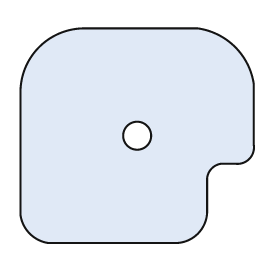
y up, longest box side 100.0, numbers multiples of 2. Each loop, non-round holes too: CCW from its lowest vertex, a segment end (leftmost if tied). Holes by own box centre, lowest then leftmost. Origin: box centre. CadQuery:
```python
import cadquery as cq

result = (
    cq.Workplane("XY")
    .moveTo(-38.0, -46.0)
    .lineTo(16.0, -46.0)
    .threePointArc((26.0, -42.0), (30.0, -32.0))
    .lineTo(30.0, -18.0)
    .threePointArc((32.0, -14.0), (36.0, -12.0))
    .lineTo(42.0, -12.0)
    .threePointArc((48.0, -10.0), (50.0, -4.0))
    .lineTo(50.0, 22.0)
    .threePointArc((42.0, 38.0), (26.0, 46.0))
    .lineTo(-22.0, 46.0)
    .threePointArc((-42.0, 38.0), (-50.0, 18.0))
    .lineTo(-50.0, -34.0)
    .threePointArc((-46.0, -42.0), (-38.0, -46.0))
    .close()
    .moveTo(0.0, 0.0)
    .circle(6.0)
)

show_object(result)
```